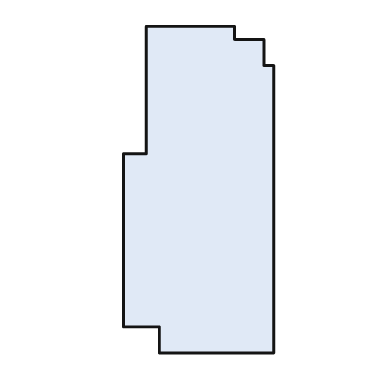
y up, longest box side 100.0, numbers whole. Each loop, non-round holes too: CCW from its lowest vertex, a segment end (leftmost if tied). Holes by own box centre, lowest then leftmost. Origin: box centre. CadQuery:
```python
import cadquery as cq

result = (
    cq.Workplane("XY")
    .moveTo(-12.0, -50.0)
    .lineTo(23.0, -50.0)
    .lineTo(23.0, 38.0)
    .lineTo(20.0, 38.0)
    .lineTo(20.0, 46.0)
    .lineTo(11.0, 46.0)
    .lineTo(11.0, 50.0)
    .lineTo(-16.0, 50.0)
    .lineTo(-16.0, 11.0)
    .lineTo(-23.0, 11.0)
    .lineTo(-23.0, -42.0)
    .lineTo(-12.0, -42.0)
    .close()
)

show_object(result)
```